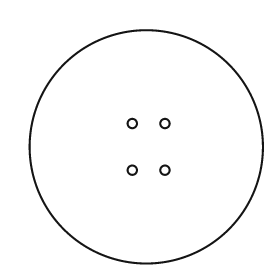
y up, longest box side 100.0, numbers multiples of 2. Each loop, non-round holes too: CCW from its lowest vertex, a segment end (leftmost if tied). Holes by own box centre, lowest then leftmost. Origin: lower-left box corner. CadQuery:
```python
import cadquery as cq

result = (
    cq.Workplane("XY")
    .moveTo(50.0, 50.0)
    .circle(50.0)
    .moveTo(44.0, 40.0)
    .circle(2.0)
    .moveTo(58.0, 40.0)
    .circle(2.0)
    .moveTo(44.0, 60.0)
    .circle(2.0)
    .moveTo(58.0, 60.0)
    .circle(2.0)
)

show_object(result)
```